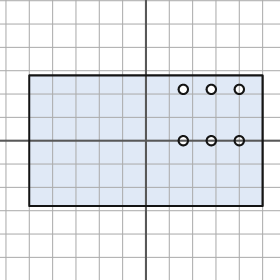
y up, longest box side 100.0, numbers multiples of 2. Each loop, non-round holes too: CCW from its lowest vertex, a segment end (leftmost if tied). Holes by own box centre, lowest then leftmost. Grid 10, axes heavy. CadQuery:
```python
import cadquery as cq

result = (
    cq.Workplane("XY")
    .moveTo(-50.0, -28.0)
    .lineTo(50.0, -28.0)
    .lineTo(50.0, 28.0)
    .lineTo(-50.0, 28.0)
    .close()
    .moveTo(16.0, 0.0)
    .circle(2.0)
    .moveTo(28.0, 0.0)
    .circle(2.0)
    .moveTo(40.0, 0.0)
    .circle(2.0)
    .moveTo(16.0, 22.0)
    .circle(2.0)
    .moveTo(28.0, 22.0)
    .circle(2.0)
    .moveTo(40.0, 22.0)
    .circle(2.0)
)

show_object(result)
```